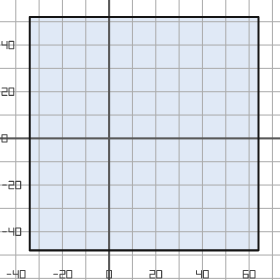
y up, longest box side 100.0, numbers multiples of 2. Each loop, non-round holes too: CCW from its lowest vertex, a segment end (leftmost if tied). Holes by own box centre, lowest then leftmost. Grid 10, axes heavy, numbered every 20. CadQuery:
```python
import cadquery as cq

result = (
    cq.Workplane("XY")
    .moveTo(-34.0, -48.0)
    .lineTo(64.0, -48.0)
    .lineTo(64.0, 52.0)
    .lineTo(-34.0, 52.0)
    .close()
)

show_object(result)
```